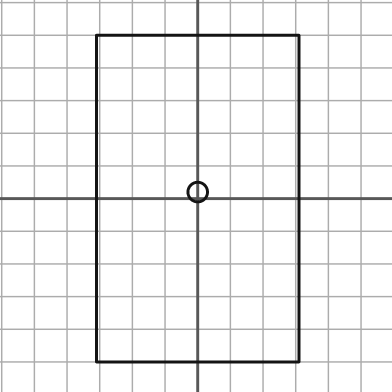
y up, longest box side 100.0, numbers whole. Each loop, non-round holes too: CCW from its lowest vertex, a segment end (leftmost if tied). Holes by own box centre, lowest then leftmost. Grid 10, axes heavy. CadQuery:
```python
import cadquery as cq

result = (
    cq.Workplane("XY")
    .moveTo(-31.0, -50.0)
    .lineTo(31.0, -50.0)
    .lineTo(31.0, 50.0)
    .lineTo(-31.0, 50.0)
    .close()
    .moveTo(0.0, 2.0)
    .circle(3.0)
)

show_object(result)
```